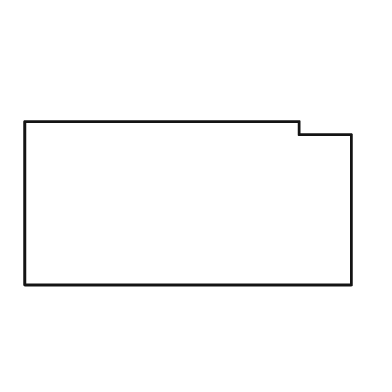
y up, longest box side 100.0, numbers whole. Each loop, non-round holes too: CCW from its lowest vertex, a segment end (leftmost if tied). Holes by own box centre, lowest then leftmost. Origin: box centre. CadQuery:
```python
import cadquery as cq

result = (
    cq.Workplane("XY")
    .moveTo(-50.0, -25.0)
    .lineTo(50.0, -25.0)
    .lineTo(50.0, 21.0)
    .lineTo(34.0, 21.0)
    .lineTo(34.0, 25.0)
    .lineTo(-50.0, 25.0)
    .close()
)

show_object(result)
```